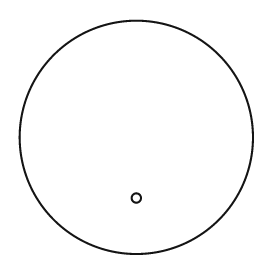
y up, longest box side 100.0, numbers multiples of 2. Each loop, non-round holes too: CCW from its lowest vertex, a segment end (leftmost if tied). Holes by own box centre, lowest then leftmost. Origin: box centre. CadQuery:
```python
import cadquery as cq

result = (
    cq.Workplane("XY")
    .moveTo(0.0, 0.0)
    .circle(50.0)
    .moveTo(0.0, -26.0)
    .circle(2.0)
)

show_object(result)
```